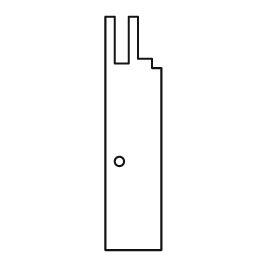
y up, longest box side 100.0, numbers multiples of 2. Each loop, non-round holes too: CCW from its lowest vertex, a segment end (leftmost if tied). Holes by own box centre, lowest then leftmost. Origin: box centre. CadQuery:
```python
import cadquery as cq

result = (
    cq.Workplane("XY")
    .moveTo(-12.0, -50.0)
    .lineTo(12.0, -50.0)
    .lineTo(12.0, 28.0)
    .lineTo(8.0, 28.0)
    .lineTo(8.0, 32.0)
    .lineTo(2.0, 32.0)
    .lineTo(2.0, 50.0)
    .lineTo(-2.0, 50.0)
    .lineTo(-2.0, 30.0)
    .lineTo(-8.0, 30.0)
    .lineTo(-8.0, 50.0)
    .lineTo(-12.0, 50.0)
    .close()
    .moveTo(-6.0, -12.0)
    .circle(2.0)
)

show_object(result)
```